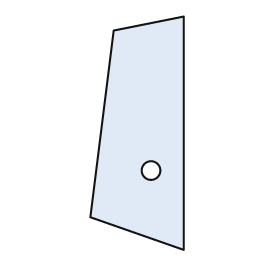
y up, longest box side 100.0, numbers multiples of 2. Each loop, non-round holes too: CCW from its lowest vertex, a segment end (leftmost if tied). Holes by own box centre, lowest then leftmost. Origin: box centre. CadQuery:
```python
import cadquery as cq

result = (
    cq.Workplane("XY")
    .moveTo(20.0, -50.0)
    .lineTo(20.0, 50.0)
    .lineTo(-10.0, 44.0)
    .lineTo(-20.0, -36.0)
    .close()
    .moveTo(6.0, -16.0)
    .circle(4.0)
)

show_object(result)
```